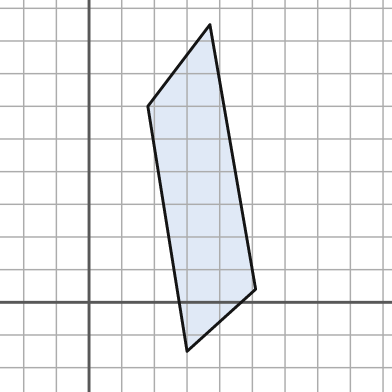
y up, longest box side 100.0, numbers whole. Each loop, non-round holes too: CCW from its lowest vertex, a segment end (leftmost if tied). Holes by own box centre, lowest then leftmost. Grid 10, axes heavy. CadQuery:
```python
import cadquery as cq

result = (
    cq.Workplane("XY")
    .moveTo(30.0, -15.0)
    .lineTo(51.0, 4.0)
    .lineTo(37.0, 85.0)
    .lineTo(18.0, 60.0)
    .close()
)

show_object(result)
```